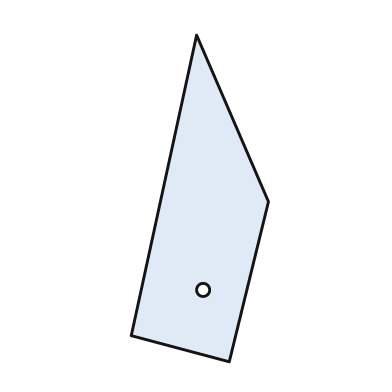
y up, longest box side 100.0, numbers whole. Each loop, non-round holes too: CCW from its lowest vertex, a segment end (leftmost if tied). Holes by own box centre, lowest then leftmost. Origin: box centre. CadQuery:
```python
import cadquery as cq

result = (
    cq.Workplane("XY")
    .moveTo(9.0, -50.0)
    .lineTo(21.0, -1.0)
    .lineTo(-1.0, 50.0)
    .lineTo(-21.0, -42.0)
    .close()
    .moveTo(1.0, -28.0)
    .circle(2.0)
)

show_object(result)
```